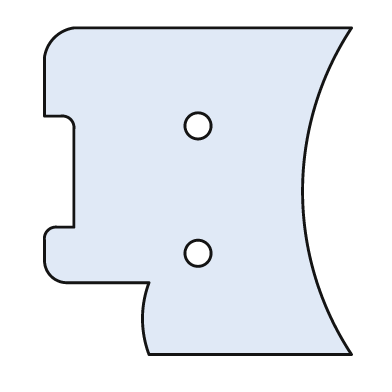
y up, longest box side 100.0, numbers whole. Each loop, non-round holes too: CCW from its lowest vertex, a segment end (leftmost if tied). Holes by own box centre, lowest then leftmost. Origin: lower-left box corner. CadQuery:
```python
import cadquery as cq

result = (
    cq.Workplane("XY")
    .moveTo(32.0, 0.0)
    .lineTo(94.0, 0.0)
    .threePointArc((79.0, 50.0), (94.0, 100.0))
    .lineTo(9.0, 100.0)
    .threePointArc((3.0, 97.0), (0.0, 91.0))
    .lineTo(0.0, 73.0)
    .lineTo(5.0, 73.0)
    .threePointArc((8.0, 72.0), (9.0, 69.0))
    .lineTo(9.0, 39.0)
    .lineTo(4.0, 39.0)
    .threePointArc((1.0, 38.0), (0.0, 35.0))
    .lineTo(0.0, 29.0)
    .threePointArc((2.0, 24.0), (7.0, 22.0))
    .lineTo(32.0, 22.0)
    .threePointArc((30.0, 11.0), (32.0, 0.0))
    .close()
    .moveTo(47.0, 31.0)
    .circle(4.0)
    .moveTo(47.0, 70.0)
    .circle(4.0)
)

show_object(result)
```